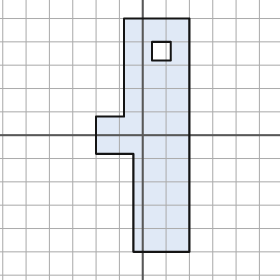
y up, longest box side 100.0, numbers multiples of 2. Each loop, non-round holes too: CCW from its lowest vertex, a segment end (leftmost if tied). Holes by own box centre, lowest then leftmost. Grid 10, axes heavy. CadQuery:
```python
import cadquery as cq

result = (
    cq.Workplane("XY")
    .moveTo(-4.0, -50.0)
    .lineTo(20.0, -50.0)
    .lineTo(20.0, 50.0)
    .lineTo(-8.0, 50.0)
    .lineTo(-8.0, 8.0)
    .lineTo(-20.0, 8.0)
    .lineTo(-20.0, -8.0)
    .lineTo(-4.0, -8.0)
    .close()
    .moveTo(4.0, 32.0)
    .lineTo(12.0, 32.0)
    .lineTo(12.0, 40.0)
    .lineTo(4.0, 40.0)
    .close()
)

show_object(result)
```